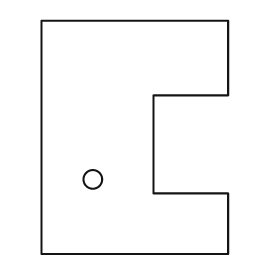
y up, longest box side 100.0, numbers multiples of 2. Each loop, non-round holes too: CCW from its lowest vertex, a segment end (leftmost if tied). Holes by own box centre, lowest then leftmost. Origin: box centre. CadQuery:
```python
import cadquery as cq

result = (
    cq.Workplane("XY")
    .moveTo(-40.0, -50.0)
    .lineTo(40.0, -50.0)
    .lineTo(40.0, -24.0)
    .lineTo(8.0, -24.0)
    .lineTo(8.0, 18.0)
    .lineTo(40.0, 18.0)
    .lineTo(40.0, 50.0)
    .lineTo(-40.0, 50.0)
    .close()
    .moveTo(-18.0, -18.0)
    .circle(4.0)
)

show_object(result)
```